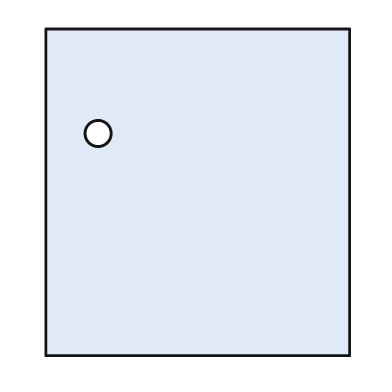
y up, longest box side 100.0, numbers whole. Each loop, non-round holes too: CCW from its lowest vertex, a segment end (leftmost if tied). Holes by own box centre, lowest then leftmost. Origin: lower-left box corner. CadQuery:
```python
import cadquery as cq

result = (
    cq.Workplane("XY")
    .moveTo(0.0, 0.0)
    .lineTo(93.0, 0.0)
    .lineTo(93.0, 100.0)
    .lineTo(0.0, 100.0)
    .close()
    .moveTo(16.0, 68.0)
    .circle(4.0)
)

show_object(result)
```